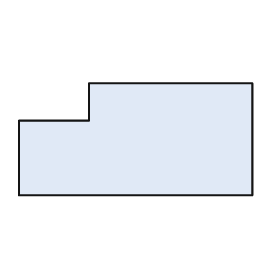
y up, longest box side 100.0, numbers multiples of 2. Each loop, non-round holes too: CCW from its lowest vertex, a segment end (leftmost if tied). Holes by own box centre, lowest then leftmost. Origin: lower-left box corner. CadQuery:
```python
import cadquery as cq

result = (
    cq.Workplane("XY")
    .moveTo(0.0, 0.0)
    .lineTo(100.0, 0.0)
    .lineTo(100.0, 48.0)
    .lineTo(30.0, 48.0)
    .lineTo(30.0, 32.0)
    .lineTo(0.0, 32.0)
    .close()
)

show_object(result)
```